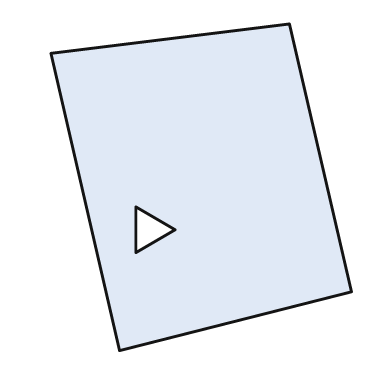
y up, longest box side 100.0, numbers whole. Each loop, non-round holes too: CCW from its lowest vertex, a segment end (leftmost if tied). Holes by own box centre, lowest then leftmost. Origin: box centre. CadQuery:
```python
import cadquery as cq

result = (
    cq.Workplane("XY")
    .moveTo(-25.0, -50.0)
    .lineTo(46.0, -32.0)
    .lineTo(27.0, 50.0)
    .lineTo(-46.0, 41.0)
    .close()
    .moveTo(-20.0, -20.0)
    .lineTo(-8.0, -13.0)
    .lineTo(-20.0, -6.0)
    .close()
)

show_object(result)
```